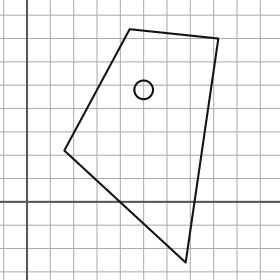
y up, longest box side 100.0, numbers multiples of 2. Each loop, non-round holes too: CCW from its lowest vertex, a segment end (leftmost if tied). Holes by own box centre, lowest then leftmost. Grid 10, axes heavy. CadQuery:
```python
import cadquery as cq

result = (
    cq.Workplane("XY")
    .moveTo(68.0, -26.0)
    .lineTo(82.0, 70.0)
    .lineTo(44.0, 74.0)
    .lineTo(16.0, 22.0)
    .close()
    .moveTo(50.0, 48.0)
    .circle(4.0)
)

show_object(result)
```